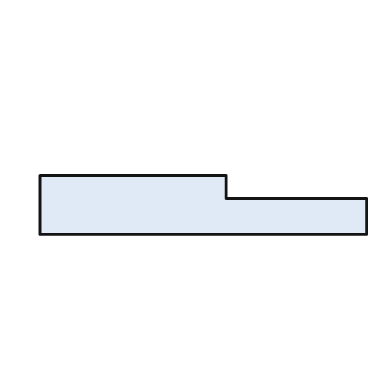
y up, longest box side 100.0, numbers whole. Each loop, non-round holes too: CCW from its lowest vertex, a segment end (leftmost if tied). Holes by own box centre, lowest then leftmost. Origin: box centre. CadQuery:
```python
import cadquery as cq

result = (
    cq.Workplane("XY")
    .moveTo(-50.0, -9.0)
    .lineTo(50.0, -9.0)
    .lineTo(50.0, 2.0)
    .lineTo(7.0, 2.0)
    .lineTo(7.0, 9.0)
    .lineTo(-50.0, 9.0)
    .close()
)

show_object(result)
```